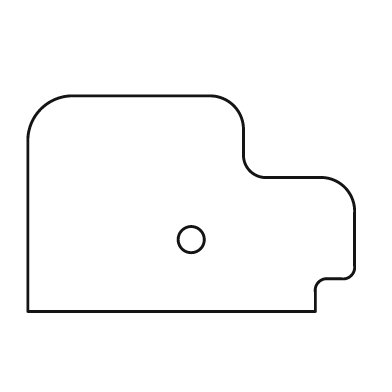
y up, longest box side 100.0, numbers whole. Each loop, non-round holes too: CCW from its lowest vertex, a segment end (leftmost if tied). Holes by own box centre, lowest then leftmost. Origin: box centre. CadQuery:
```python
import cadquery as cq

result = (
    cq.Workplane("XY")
    .moveTo(-50.0, -33.0)
    .lineTo(38.0, -33.0)
    .lineTo(38.0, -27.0)
    .threePointArc((39.0, -24.0), (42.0, -23.0))
    .lineTo(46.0, -23.0)
    .threePointArc((49.0, -22.0), (50.0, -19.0))
    .lineTo(50.0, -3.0)
    .threePointArc((47.0, 5.0), (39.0, 8.0))
    .lineTo(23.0, 8.0)
    .threePointArc((18.0, 10.0), (16.0, 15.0))
    .lineTo(16.0, 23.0)
    .threePointArc((13.0, 30.0), (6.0, 33.0))
    .lineTo(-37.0, 33.0)
    .threePointArc((-46.0, 29.0), (-50.0, 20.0))
    .close()
    .moveTo(0.0, -11.0)
    .circle(4.0)
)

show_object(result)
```